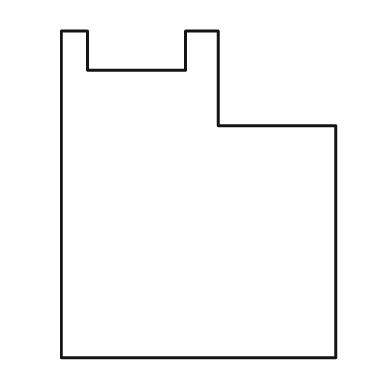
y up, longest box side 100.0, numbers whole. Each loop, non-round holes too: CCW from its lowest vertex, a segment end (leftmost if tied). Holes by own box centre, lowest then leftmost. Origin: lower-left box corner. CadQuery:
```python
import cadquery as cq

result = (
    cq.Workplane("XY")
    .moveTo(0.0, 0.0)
    .lineTo(84.0, 0.0)
    .lineTo(84.0, 71.0)
    .lineTo(48.0, 71.0)
    .lineTo(48.0, 100.0)
    .lineTo(38.0, 100.0)
    .lineTo(38.0, 88.0)
    .lineTo(8.0, 88.0)
    .lineTo(8.0, 100.0)
    .lineTo(0.0, 100.0)
    .close()
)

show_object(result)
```